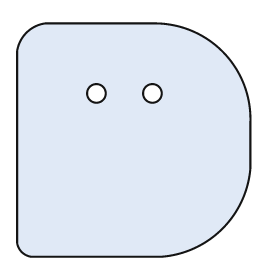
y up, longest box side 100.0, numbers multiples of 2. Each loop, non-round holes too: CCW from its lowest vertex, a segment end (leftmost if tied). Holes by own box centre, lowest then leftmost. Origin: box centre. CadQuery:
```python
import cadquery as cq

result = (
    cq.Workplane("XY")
    .moveTo(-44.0, -50.0)
    .lineTo(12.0, -50.0)
    .threePointArc((38.0, -38.0), (50.0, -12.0))
    .lineTo(50.0, 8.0)
    .threePointArc((38.0, 38.0), (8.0, 50.0))
    .lineTo(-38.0, 50.0)
    .threePointArc((-46.0, 46.0), (-50.0, 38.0))
    .lineTo(-50.0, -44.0)
    .threePointArc((-48.0, -48.0), (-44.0, -50.0))
    .close()
    .moveTo(-16.0, 20.0)
    .circle(4.0)
    .moveTo(8.0, 20.0)
    .circle(4.0)
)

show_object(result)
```